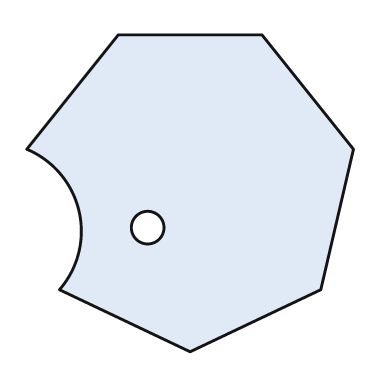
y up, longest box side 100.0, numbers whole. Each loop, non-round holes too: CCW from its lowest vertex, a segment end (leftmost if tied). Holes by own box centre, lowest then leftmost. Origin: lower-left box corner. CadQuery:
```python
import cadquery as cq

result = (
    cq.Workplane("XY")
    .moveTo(50.0, 0.0)
    .lineTo(90.0, 19.0)
    .lineTo(100.0, 62.0)
    .lineTo(72.0, 97.0)
    .lineTo(28.0, 97.0)
    .lineTo(0.0, 62.0)
    .threePointArc((16.0, 43.0), (10.0, 19.0))
    .close()
    .moveTo(37.0, 38.0)
    .circle(5.0)
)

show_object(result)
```